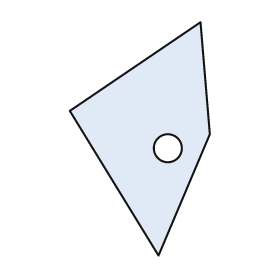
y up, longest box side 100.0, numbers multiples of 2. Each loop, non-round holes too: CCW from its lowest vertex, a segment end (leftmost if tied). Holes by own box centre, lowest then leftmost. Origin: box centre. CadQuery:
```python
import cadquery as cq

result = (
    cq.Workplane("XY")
    .moveTo(8.0, -50.0)
    .lineTo(30.0, 2.0)
    .lineTo(26.0, 50.0)
    .lineTo(-30.0, 12.0)
    .close()
    .moveTo(12.0, -4.0)
    .circle(6.0)
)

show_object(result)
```